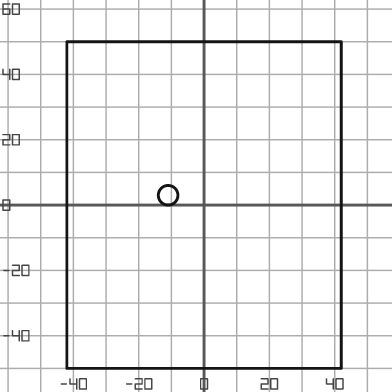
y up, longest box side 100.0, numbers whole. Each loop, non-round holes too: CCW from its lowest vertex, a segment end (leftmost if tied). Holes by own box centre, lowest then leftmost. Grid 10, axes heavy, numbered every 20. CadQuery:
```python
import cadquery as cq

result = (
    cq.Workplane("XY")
    .moveTo(-42.0, -50.0)
    .lineTo(42.0, -50.0)
    .lineTo(42.0, 50.0)
    .lineTo(-42.0, 50.0)
    .close()
    .moveTo(-11.0, 3.0)
    .circle(3.0)
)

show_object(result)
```